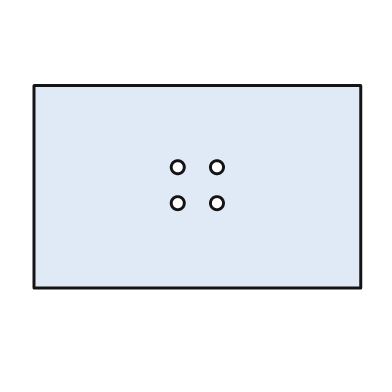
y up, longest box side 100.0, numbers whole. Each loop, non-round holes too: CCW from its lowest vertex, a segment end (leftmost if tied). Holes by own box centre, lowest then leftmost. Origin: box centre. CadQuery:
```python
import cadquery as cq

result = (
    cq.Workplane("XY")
    .moveTo(-50.0, -31.0)
    .lineTo(50.0, -31.0)
    .lineTo(50.0, 31.0)
    .lineTo(-50.0, 31.0)
    .close()
    .moveTo(-6.0, -5.0)
    .circle(2.0)
    .moveTo(6.0, -5.0)
    .circle(2.0)
    .moveTo(-6.0, 6.0)
    .circle(2.0)
    .moveTo(6.0, 6.0)
    .circle(2.0)
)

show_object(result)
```